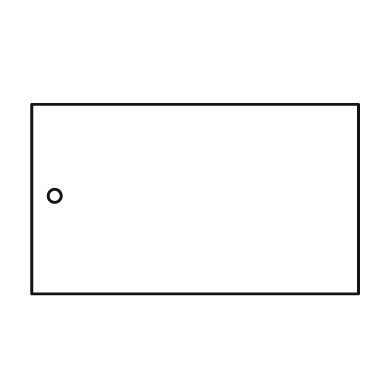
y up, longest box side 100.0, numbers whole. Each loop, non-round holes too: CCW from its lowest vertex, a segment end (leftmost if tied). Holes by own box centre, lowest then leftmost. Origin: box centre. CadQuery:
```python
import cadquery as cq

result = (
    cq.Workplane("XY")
    .moveTo(-50.0, -29.0)
    .lineTo(50.0, -29.0)
    .lineTo(50.0, 29.0)
    .lineTo(-50.0, 29.0)
    .close()
    .moveTo(-43.0, 1.0)
    .circle(2.0)
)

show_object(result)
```